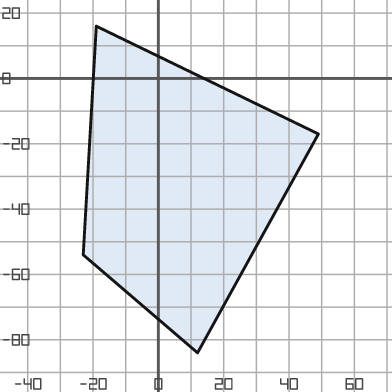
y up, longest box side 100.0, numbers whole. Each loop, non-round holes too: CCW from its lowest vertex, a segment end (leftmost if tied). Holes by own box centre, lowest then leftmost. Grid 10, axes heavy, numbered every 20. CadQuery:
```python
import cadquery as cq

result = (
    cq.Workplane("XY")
    .moveTo(12.0, -84.0)
    .lineTo(49.0, -17.0)
    .lineTo(-19.0, 16.0)
    .lineTo(-23.0, -54.0)
    .close()
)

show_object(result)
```